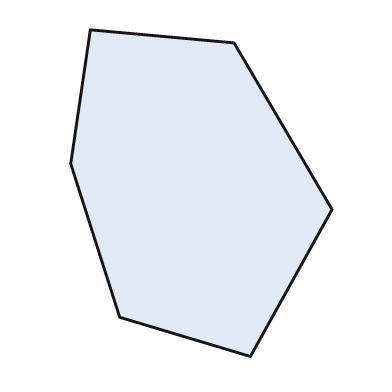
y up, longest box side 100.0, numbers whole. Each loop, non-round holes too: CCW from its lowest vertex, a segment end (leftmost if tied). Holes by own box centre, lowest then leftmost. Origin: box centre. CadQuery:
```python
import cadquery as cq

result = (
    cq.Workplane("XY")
    .moveTo(15.0, -50.0)
    .lineTo(40.0, -5.0)
    .lineTo(10.0, 46.0)
    .lineTo(-34.0, 50.0)
    .lineTo(-40.0, 9.0)
    .lineTo(-25.0, -38.0)
    .close()
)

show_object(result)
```